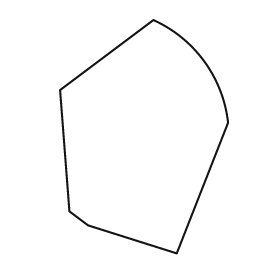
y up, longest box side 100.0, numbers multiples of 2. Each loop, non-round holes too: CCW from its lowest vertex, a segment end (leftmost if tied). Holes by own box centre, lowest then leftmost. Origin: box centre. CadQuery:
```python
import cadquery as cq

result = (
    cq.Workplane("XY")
    .moveTo(14.0, -50.0)
    .lineTo(36.0, 6.0)
    .threePointArc((26.0, 32.0), (4.0, 50.0))
    .lineTo(-36.0, 20.0)
    .lineTo(-32.0, -32.0)
    .lineTo(-24.0, -38.0)
    .close()
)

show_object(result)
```